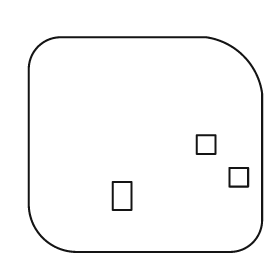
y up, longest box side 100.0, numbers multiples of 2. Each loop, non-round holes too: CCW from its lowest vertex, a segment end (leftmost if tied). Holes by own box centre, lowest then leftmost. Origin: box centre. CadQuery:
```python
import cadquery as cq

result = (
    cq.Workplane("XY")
    .moveTo(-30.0, -46.0)
    .lineTo(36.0, -46.0)
    .threePointArc((46.0, -42.0), (50.0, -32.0))
    .lineTo(50.0, 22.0)
    .threePointArc((42.0, 38.0), (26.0, 46.0))
    .lineTo(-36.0, 46.0)
    .threePointArc((-46.0, 42.0), (-50.0, 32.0))
    .lineTo(-50.0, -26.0)
    .threePointArc((-44.0, -40.0), (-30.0, -46.0))
    .close()
    .moveTo(-14.0, -28.0)
    .lineTo(-6.0, -28.0)
    .lineTo(-6.0, -16.0)
    .lineTo(-14.0, -16.0)
    .close()
    .moveTo(36.0, -18.0)
    .lineTo(44.0, -18.0)
    .lineTo(44.0, -10.0)
    .lineTo(36.0, -10.0)
    .close()
    .moveTo(22.0, -4.0)
    .lineTo(30.0, -4.0)
    .lineTo(30.0, 4.0)
    .lineTo(22.0, 4.0)
    .close()
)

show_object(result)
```